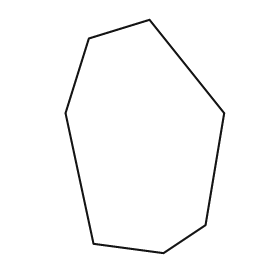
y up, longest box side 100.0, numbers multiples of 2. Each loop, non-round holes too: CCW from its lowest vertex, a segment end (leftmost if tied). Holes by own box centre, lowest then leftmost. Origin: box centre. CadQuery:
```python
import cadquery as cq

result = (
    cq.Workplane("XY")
    .moveTo(8.0, -50.0)
    .lineTo(26.0, -38.0)
    .lineTo(34.0, 10.0)
    .lineTo(2.0, 50.0)
    .lineTo(-24.0, 42.0)
    .lineTo(-34.0, 10.0)
    .lineTo(-22.0, -46.0)
    .close()
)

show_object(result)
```